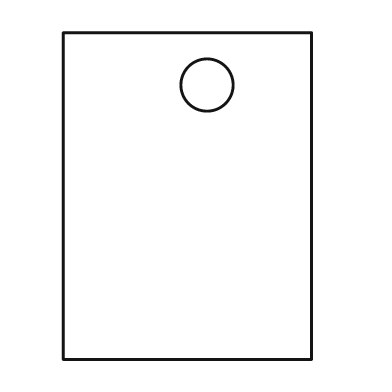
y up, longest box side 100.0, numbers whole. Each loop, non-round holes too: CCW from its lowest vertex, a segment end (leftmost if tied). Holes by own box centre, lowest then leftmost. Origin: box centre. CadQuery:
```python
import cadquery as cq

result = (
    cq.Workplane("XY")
    .moveTo(-38.0, -50.0)
    .lineTo(38.0, -50.0)
    .lineTo(38.0, 50.0)
    .lineTo(-38.0, 50.0)
    .close()
    .moveTo(6.0, 34.0)
    .circle(8.0)
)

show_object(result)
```